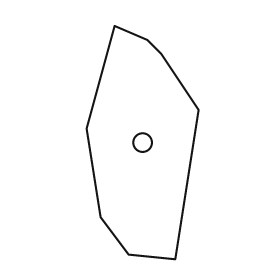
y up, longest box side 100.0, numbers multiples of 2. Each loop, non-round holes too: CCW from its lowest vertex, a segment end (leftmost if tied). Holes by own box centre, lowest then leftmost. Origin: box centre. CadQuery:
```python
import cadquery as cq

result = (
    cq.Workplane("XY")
    .moveTo(14.0, -50.0)
    .lineTo(24.0, 14.0)
    .lineTo(8.0, 38.0)
    .lineTo(2.0, 44.0)
    .lineTo(-12.0, 50.0)
    .lineTo(-24.0, 6.0)
    .lineTo(-18.0, -32.0)
    .lineTo(-6.0, -48.0)
    .close()
    .moveTo(0.0, 0.0)
    .circle(4.0)
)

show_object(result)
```